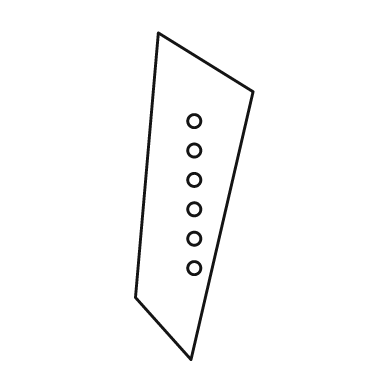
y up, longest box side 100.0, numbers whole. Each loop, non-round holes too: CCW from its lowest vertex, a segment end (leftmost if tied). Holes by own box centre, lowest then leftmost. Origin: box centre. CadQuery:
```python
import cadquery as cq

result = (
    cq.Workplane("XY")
    .moveTo(-1.0, -50.0)
    .lineTo(18.0, 32.0)
    .lineTo(-11.0, 50.0)
    .lineTo(-18.0, -31.0)
    .close()
    .moveTo(0.0, -22.0)
    .circle(2.0)
    .moveTo(0.0, -13.0)
    .circle(2.0)
    .moveTo(0.0, -4.0)
    .circle(2.0)
    .moveTo(0.0, 5.0)
    .circle(2.0)
    .moveTo(0.0, 14.0)
    .circle(2.0)
    .moveTo(0.0, 23.0)
    .circle(2.0)
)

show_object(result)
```